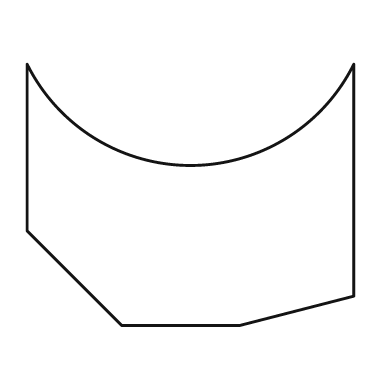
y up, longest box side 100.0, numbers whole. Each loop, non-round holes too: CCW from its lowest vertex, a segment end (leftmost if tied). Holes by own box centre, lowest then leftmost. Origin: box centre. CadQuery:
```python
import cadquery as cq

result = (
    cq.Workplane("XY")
    .moveTo(-21.0, -40.0)
    .lineTo(15.0, -40.0)
    .lineTo(50.0, -31.0)
    .lineTo(50.0, 40.0)
    .threePointArc((0.0, 9.0), (-50.0, 40.0))
    .lineTo(-50.0, -11.0)
    .close()
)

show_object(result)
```